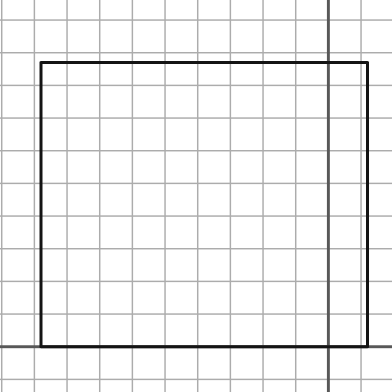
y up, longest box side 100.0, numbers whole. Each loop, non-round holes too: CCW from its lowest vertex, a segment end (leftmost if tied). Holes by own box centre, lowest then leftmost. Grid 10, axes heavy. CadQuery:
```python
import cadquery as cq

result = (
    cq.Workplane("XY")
    .moveTo(-88.0, 0.0)
    .lineTo(12.0, 0.0)
    .lineTo(12.0, 87.0)
    .lineTo(-88.0, 87.0)
    .close()
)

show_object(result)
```